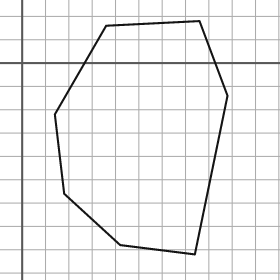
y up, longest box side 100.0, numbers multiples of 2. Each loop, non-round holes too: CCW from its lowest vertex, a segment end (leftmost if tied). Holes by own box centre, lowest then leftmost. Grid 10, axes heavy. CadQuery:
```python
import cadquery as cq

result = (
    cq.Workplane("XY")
    .moveTo(74.0, -82.0)
    .lineTo(88.0, -14.0)
    .lineTo(76.0, 18.0)
    .lineTo(36.0, 16.0)
    .lineTo(14.0, -22.0)
    .lineTo(18.0, -56.0)
    .lineTo(42.0, -78.0)
    .close()
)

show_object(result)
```